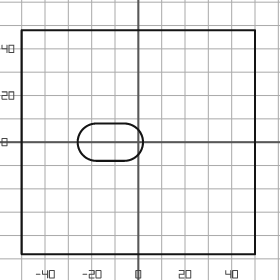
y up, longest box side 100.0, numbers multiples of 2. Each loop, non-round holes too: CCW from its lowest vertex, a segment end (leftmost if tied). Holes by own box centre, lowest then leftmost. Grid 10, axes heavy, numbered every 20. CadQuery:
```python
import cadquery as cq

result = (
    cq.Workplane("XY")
    .moveTo(-50.0, -48.0)
    .lineTo(50.0, -48.0)
    .lineTo(50.0, 48.0)
    .lineTo(-50.0, 48.0)
    .close()
    .moveTo(-18.0, -8.0)
    .lineTo(-6.0, -8.0)
    .threePointArc((2.0, 0.0), (-6.0, 8.0))
    .lineTo(-18.0, 8.0)
    .threePointArc((-26.0, 0.0), (-18.0, -8.0))
    .close()
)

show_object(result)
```